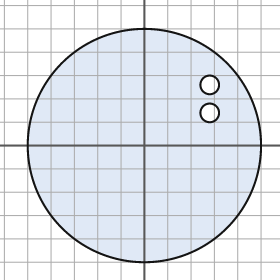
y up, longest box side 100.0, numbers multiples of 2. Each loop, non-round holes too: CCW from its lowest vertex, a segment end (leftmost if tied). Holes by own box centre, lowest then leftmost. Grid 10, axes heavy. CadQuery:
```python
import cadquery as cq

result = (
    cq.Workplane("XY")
    .moveTo(0.0, 0.0)
    .circle(50.0)
    .moveTo(28.0, 14.0)
    .circle(4.0)
    .moveTo(28.0, 26.0)
    .circle(4.0)
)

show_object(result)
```